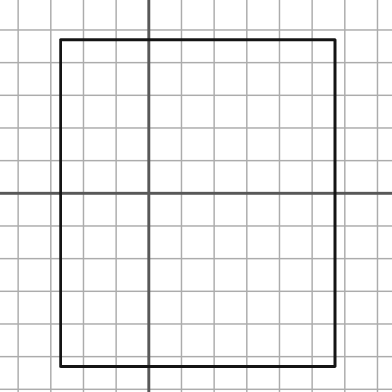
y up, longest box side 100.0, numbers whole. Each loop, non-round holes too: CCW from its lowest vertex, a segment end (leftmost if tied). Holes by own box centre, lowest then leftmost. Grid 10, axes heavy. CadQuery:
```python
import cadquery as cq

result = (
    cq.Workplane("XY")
    .moveTo(-27.0, -53.0)
    .lineTo(57.0, -53.0)
    .lineTo(57.0, 47.0)
    .lineTo(-27.0, 47.0)
    .close()
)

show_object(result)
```